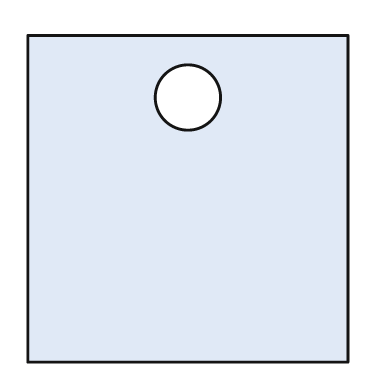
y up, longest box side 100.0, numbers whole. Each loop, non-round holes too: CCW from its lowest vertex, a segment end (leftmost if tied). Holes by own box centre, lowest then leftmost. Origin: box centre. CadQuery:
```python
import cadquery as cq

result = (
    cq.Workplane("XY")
    .moveTo(-49.0, -50.0)
    .lineTo(49.0, -50.0)
    .lineTo(49.0, 50.0)
    .lineTo(-49.0, 50.0)
    .close()
    .moveTo(0.0, 31.0)
    .circle(10.0)
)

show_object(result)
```